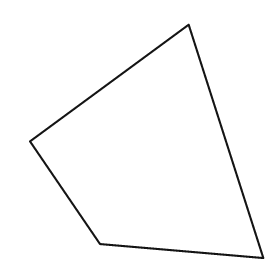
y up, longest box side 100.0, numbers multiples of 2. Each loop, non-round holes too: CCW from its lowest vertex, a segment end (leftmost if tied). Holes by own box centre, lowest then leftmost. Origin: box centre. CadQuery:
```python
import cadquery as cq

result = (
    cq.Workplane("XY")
    .moveTo(50.0, -50.0)
    .lineTo(18.0, 50.0)
    .lineTo(-50.0, 0.0)
    .lineTo(-20.0, -44.0)
    .close()
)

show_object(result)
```